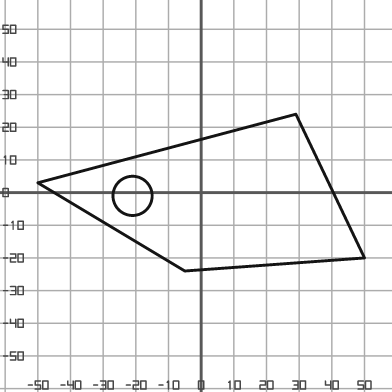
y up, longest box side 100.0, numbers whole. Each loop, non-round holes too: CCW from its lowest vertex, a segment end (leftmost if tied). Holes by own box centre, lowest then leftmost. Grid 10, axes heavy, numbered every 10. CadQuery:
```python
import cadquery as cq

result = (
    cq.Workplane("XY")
    .moveTo(-5.0, -24.0)
    .lineTo(50.0, -20.0)
    .lineTo(29.0, 24.0)
    .lineTo(-50.0, 3.0)
    .close()
    .moveTo(-21.0, -1.0)
    .circle(6.0)
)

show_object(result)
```